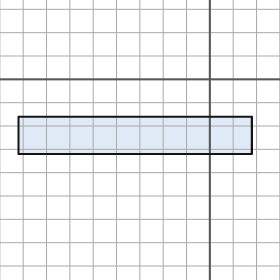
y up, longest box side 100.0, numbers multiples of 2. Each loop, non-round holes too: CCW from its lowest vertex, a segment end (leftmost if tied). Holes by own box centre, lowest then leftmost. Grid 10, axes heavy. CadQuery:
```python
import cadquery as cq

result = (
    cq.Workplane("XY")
    .moveTo(-82.0, -32.0)
    .lineTo(18.0, -32.0)
    .lineTo(18.0, -16.0)
    .lineTo(-82.0, -16.0)
    .close()
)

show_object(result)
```